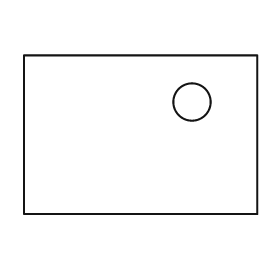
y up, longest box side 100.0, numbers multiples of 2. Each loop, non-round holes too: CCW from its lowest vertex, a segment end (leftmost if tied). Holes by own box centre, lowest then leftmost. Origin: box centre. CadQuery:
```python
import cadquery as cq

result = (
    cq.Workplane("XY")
    .moveTo(-50.0, -34.0)
    .lineTo(50.0, -34.0)
    .lineTo(50.0, 34.0)
    .lineTo(-50.0, 34.0)
    .close()
    .moveTo(22.0, 14.0)
    .circle(8.0)
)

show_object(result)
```